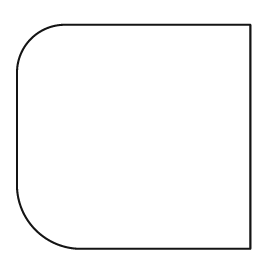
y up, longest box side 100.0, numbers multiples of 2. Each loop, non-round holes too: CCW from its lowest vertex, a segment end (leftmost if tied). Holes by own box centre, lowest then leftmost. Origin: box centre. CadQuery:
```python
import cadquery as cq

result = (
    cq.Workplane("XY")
    .moveTo(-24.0, -48.0)
    .lineTo(50.0, -48.0)
    .lineTo(50.0, 48.0)
    .lineTo(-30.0, 48.0)
    .threePointArc((-44.0, 42.0), (-50.0, 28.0))
    .lineTo(-50.0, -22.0)
    .threePointArc((-42.0, -40.0), (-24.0, -48.0))
    .close()
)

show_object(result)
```